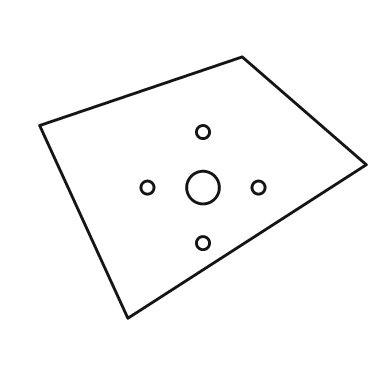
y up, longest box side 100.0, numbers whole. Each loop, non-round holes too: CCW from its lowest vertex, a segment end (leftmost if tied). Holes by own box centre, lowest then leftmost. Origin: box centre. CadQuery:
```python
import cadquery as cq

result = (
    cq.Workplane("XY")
    .moveTo(-23.0, -40.0)
    .lineTo(50.0, 7.0)
    .lineTo(12.0, 40.0)
    .lineTo(-50.0, 19.0)
    .close()
    .moveTo(0.0, -17.0)
    .circle(2.0)
    .moveTo(-17.0, 0.0)
    .circle(2.0)
    .moveTo(0.0, 0.0)
    .circle(5.0)
    .moveTo(17.0, 0.0)
    .circle(2.0)
    .moveTo(0.0, 17.0)
    .circle(2.0)
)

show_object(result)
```